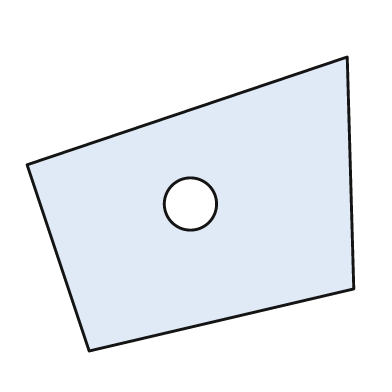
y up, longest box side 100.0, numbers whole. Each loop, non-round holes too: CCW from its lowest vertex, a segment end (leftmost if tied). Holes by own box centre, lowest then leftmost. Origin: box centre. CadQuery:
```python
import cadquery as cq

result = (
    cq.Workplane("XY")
    .moveTo(-31.0, -45.0)
    .lineTo(50.0, -26.0)
    .lineTo(48.0, 45.0)
    .lineTo(-50.0, 12.0)
    .close()
    .moveTo(0.0, 0.0)
    .circle(8.0)
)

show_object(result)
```